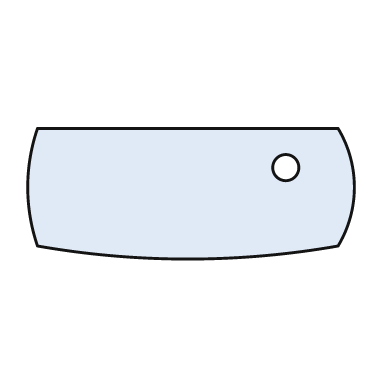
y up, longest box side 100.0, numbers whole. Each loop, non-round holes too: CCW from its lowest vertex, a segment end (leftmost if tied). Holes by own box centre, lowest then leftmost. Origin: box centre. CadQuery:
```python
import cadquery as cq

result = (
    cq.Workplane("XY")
    .moveTo(-47.0, -16.0)
    .threePointArc((-1.0, -20.0), (45.0, -16.0))
    .threePointArc((50.0, 2.0), (45.0, 20.0))
    .lineTo(-47.0, 20.0)
    .threePointArc((-50.0, 2.0), (-47.0, -16.0))
    .close()
    .moveTo(29.0, 8.0)
    .circle(4.0)
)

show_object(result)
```